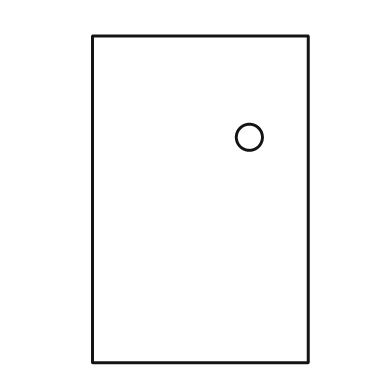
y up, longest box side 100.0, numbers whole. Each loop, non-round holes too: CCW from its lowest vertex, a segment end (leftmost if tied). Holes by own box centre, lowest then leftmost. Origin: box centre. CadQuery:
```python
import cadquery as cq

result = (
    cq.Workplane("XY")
    .moveTo(-33.0, -50.0)
    .lineTo(33.0, -50.0)
    .lineTo(33.0, 50.0)
    .lineTo(-33.0, 50.0)
    .close()
    .moveTo(15.0, 19.0)
    .circle(4.0)
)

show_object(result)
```